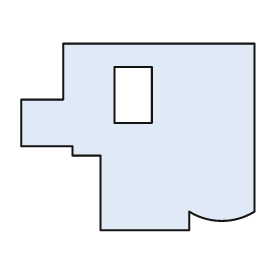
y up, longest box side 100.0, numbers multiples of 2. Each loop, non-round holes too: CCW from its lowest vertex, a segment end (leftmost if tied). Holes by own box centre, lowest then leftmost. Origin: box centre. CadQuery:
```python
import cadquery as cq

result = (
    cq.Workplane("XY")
    .moveTo(-16.0, -40.0)
    .lineTo(22.0, -40.0)
    .lineTo(22.0, -32.0)
    .threePointArc((36.0, -36.0), (50.0, -32.0))
    .lineTo(50.0, 40.0)
    .lineTo(-32.0, 40.0)
    .lineTo(-32.0, 16.0)
    .lineTo(-50.0, 16.0)
    .lineTo(-50.0, -4.0)
    .lineTo(-28.0, -4.0)
    .lineTo(-28.0, -8.0)
    .lineTo(-16.0, -8.0)
    .close()
    .moveTo(-10.0, 6.0)
    .lineTo(6.0, 6.0)
    .lineTo(6.0, 30.0)
    .lineTo(-10.0, 30.0)
    .close()
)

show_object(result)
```